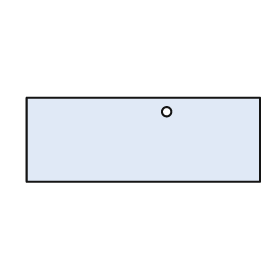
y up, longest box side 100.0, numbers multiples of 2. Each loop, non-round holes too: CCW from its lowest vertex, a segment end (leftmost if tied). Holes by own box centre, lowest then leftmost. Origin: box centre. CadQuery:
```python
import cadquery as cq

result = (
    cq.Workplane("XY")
    .moveTo(-50.0, -18.0)
    .lineTo(50.0, -18.0)
    .lineTo(50.0, 18.0)
    .lineTo(-50.0, 18.0)
    .close()
    .moveTo(10.0, 12.0)
    .circle(2.0)
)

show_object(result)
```